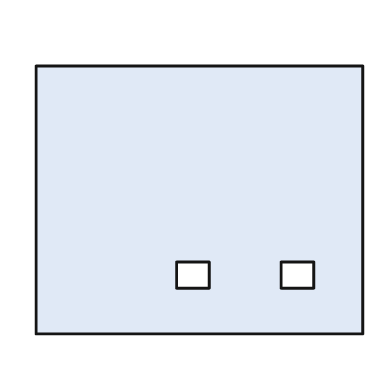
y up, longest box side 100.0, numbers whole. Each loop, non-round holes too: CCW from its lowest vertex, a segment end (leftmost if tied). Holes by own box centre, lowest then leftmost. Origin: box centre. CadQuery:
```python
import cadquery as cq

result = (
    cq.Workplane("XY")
    .moveTo(-50.0, -41.0)
    .lineTo(50.0, -41.0)
    .lineTo(50.0, 41.0)
    .lineTo(-50.0, 41.0)
    .close()
    .moveTo(-7.0, -27.0)
    .lineTo(3.0, -27.0)
    .lineTo(3.0, -19.0)
    .lineTo(-7.0, -19.0)
    .close()
    .moveTo(25.0, -27.0)
    .lineTo(35.0, -27.0)
    .lineTo(35.0, -19.0)
    .lineTo(25.0, -19.0)
    .close()
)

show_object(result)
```